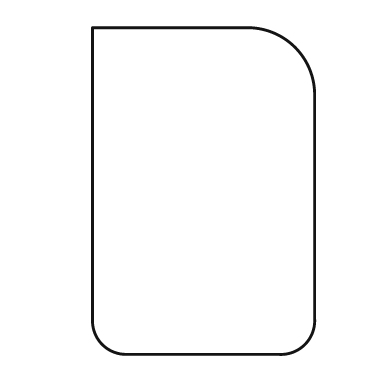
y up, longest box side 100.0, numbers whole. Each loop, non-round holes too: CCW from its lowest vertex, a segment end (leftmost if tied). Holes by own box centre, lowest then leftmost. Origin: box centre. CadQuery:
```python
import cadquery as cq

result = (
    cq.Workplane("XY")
    .moveTo(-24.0, -50.0)
    .lineTo(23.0, -50.0)
    .threePointArc((31.0, -47.0), (34.0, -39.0))
    .lineTo(34.0, 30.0)
    .threePointArc((28.0, 44.0), (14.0, 50.0))
    .lineTo(-34.0, 50.0)
    .lineTo(-34.0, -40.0)
    .threePointArc((-31.0, -47.0), (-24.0, -50.0))
    .close()
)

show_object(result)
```